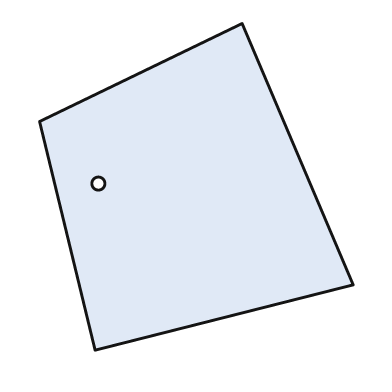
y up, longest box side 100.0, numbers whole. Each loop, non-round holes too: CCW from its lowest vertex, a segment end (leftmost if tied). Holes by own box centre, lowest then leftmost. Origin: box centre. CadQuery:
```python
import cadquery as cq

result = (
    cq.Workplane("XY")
    .moveTo(-31.0, -50.0)
    .lineTo(48.0, -30.0)
    .lineTo(14.0, 50.0)
    .lineTo(-48.0, 20.0)
    .close()
    .moveTo(-30.0, 1.0)
    .circle(2.0)
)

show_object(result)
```